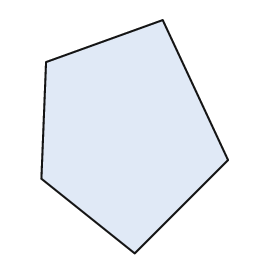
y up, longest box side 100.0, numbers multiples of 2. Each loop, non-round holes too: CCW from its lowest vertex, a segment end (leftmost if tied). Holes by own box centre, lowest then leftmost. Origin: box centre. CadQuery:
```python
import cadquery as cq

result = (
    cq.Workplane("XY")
    .moveTo(0.0, -50.0)
    .lineTo(40.0, -10.0)
    .lineTo(12.0, 50.0)
    .lineTo(-38.0, 32.0)
    .lineTo(-40.0, -18.0)
    .close()
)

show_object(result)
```